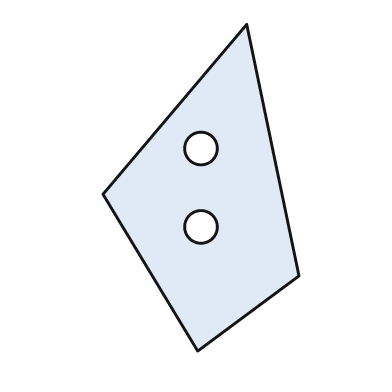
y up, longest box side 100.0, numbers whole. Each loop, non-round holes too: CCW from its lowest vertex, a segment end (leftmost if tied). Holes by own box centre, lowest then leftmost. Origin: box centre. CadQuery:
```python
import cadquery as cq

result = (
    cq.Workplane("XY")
    .moveTo(-1.0, -50.0)
    .lineTo(30.0, -27.0)
    .lineTo(14.0, 50.0)
    .lineTo(-30.0, -2.0)
    .close()
    .moveTo(0.0, -12.0)
    .circle(5.0)
    .moveTo(0.0, 12.0)
    .circle(5.0)
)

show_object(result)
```